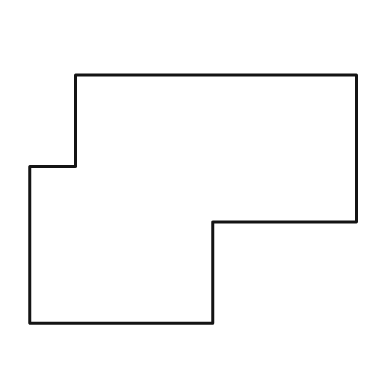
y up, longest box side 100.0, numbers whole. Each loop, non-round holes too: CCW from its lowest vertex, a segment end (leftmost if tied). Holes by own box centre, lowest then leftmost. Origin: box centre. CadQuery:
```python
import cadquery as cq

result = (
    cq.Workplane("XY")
    .moveTo(-50.0, -38.0)
    .lineTo(6.0, -38.0)
    .lineTo(6.0, -7.0)
    .lineTo(50.0, -7.0)
    .lineTo(50.0, 38.0)
    .lineTo(-36.0, 38.0)
    .lineTo(-36.0, 10.0)
    .lineTo(-50.0, 10.0)
    .close()
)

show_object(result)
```